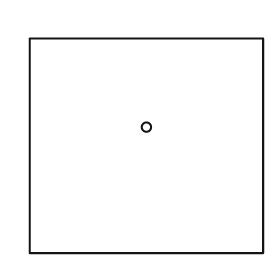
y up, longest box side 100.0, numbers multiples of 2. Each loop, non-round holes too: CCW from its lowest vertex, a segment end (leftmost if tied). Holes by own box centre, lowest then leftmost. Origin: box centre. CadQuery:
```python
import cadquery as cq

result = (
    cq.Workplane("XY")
    .moveTo(-50.0, -46.0)
    .lineTo(50.0, -46.0)
    .lineTo(50.0, 46.0)
    .lineTo(-50.0, 46.0)
    .close()
    .moveTo(0.0, 8.0)
    .circle(2.0)
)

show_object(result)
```